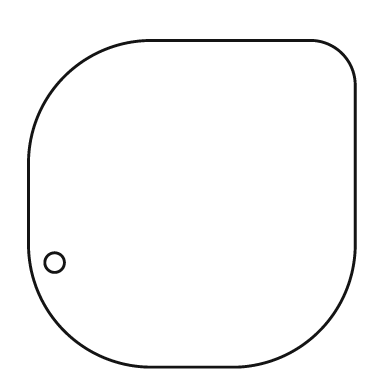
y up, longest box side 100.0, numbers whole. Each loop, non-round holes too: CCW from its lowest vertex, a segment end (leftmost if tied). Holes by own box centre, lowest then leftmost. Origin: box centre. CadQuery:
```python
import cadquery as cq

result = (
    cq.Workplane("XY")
    .moveTo(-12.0, -50.0)
    .lineTo(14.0, -50.0)
    .threePointArc((39.0, -39.0), (50.0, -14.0))
    .lineTo(50.0, 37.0)
    .threePointArc((46.0, 46.0), (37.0, 50.0))
    .lineTo(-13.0, 50.0)
    .threePointArc((-39.0, 39.0), (-50.0, 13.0))
    .lineTo(-50.0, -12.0)
    .threePointArc((-39.0, -39.0), (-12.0, -50.0))
    .close()
    .moveTo(-42.0, -18.0)
    .circle(3.0)
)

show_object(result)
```